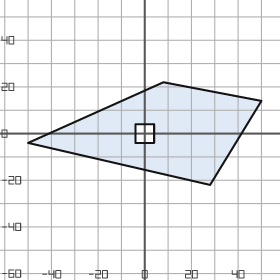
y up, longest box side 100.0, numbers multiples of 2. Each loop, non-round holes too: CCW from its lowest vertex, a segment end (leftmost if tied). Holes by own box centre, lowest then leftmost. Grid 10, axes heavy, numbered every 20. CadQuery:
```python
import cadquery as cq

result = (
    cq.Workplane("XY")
    .moveTo(28.0, -22.0)
    .lineTo(50.0, 14.0)
    .lineTo(8.0, 22.0)
    .lineTo(-50.0, -4.0)
    .close()
    .moveTo(-4.0, -4.0)
    .lineTo(4.0, -4.0)
    .lineTo(4.0, 4.0)
    .lineTo(-4.0, 4.0)
    .close()
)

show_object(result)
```